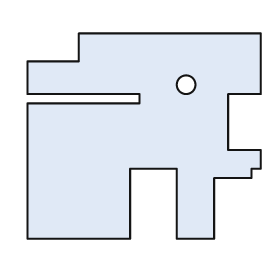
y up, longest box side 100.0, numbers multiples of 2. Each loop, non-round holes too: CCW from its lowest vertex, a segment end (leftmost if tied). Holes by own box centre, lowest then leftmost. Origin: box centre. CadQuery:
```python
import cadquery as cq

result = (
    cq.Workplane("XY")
    .moveTo(-50.0, -44.0)
    .lineTo(-6.0, -44.0)
    .lineTo(-6.0, -14.0)
    .lineTo(14.0, -14.0)
    .lineTo(14.0, -44.0)
    .lineTo(30.0, -44.0)
    .lineTo(30.0, -18.0)
    .lineTo(46.0, -18.0)
    .lineTo(46.0, -14.0)
    .lineTo(50.0, -14.0)
    .lineTo(50.0, -6.0)
    .lineTo(36.0, -6.0)
    .lineTo(36.0, 18.0)
    .lineTo(50.0, 18.0)
    .lineTo(50.0, 44.0)
    .lineTo(-28.0, 44.0)
    .lineTo(-28.0, 32.0)
    .lineTo(-50.0, 32.0)
    .lineTo(-50.0, 18.0)
    .lineTo(-2.0, 18.0)
    .lineTo(-2.0, 14.0)
    .lineTo(-50.0, 14.0)
    .close()
    .moveTo(18.0, 22.0)
    .circle(4.0)
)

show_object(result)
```